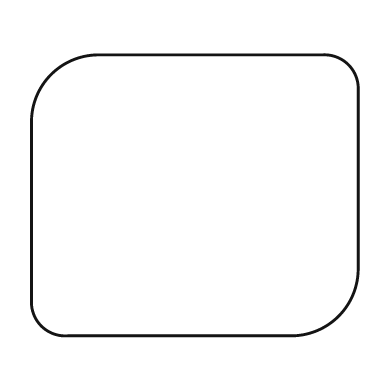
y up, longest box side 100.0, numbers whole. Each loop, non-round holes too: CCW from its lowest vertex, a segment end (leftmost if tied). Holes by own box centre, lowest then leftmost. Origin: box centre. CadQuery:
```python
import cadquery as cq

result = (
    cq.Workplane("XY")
    .moveTo(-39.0, -43.0)
    .lineTo(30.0, -43.0)
    .threePointArc((44.0, -37.0), (50.0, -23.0))
    .lineTo(50.0, 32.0)
    .threePointArc((47.0, 40.0), (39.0, 43.0))
    .lineTo(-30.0, 43.0)
    .threePointArc((-44.0, 37.0), (-50.0, 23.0))
    .lineTo(-50.0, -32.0)
    .threePointArc((-47.0, -40.0), (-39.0, -43.0))
    .close()
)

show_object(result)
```